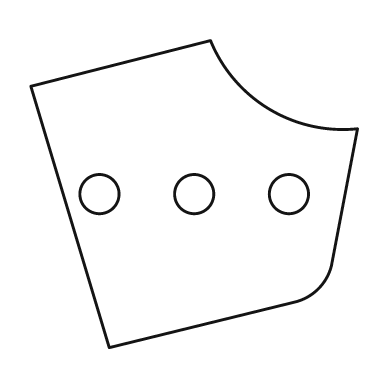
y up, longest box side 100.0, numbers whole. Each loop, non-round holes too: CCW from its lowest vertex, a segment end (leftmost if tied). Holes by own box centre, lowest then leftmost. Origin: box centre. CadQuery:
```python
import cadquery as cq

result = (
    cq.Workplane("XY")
    .moveTo(-26.0, -47.0)
    .lineTo(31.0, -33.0)
    .threePointArc((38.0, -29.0), (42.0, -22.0))
    .lineTo(50.0, 20.0)
    .threePointArc((23.0, 26.0), (5.0, 47.0))
    .lineTo(-50.0, 33.0)
    .close()
    .moveTo(-29.0, 0.0)
    .circle(6.0)
    .moveTo(0.0, 0.0)
    .circle(6.0)
    .moveTo(29.0, 0.0)
    .circle(6.0)
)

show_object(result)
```